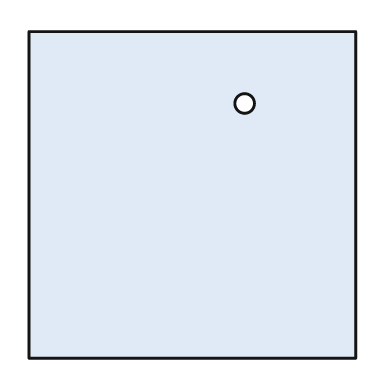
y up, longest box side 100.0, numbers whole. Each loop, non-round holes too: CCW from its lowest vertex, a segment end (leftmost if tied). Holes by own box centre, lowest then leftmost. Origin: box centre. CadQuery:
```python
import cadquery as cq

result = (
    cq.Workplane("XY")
    .moveTo(-50.0, -50.0)
    .lineTo(50.0, -50.0)
    .lineTo(50.0, 50.0)
    .lineTo(-50.0, 50.0)
    .close()
    .moveTo(16.0, 28.0)
    .circle(3.0)
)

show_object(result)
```